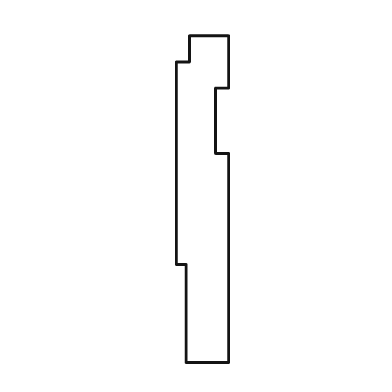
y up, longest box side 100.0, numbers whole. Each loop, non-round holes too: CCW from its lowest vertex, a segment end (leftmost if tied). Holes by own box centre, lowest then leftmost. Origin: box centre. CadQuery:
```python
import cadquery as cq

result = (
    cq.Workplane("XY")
    .moveTo(-5.0, -50.0)
    .lineTo(8.0, -50.0)
    .lineTo(8.0, 14.0)
    .lineTo(4.0, 14.0)
    .lineTo(4.0, 34.0)
    .lineTo(8.0, 34.0)
    .lineTo(8.0, 50.0)
    .lineTo(-4.0, 50.0)
    .lineTo(-4.0, 42.0)
    .lineTo(-8.0, 42.0)
    .lineTo(-8.0, -20.0)
    .lineTo(-5.0, -20.0)
    .close()
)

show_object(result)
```